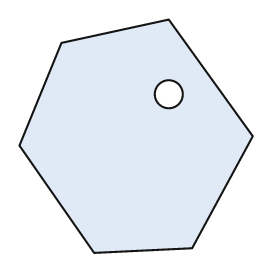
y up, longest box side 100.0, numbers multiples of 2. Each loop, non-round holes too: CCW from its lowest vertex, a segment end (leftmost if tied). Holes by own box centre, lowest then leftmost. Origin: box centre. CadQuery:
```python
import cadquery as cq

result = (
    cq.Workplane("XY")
    .moveTo(-18.0, -50.0)
    .lineTo(24.0, -48.0)
    .lineTo(50.0, 0.0)
    .lineTo(14.0, 50.0)
    .lineTo(-32.0, 40.0)
    .lineTo(-50.0, -4.0)
    .close()
    .moveTo(14.0, 18.0)
    .circle(6.0)
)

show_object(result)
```